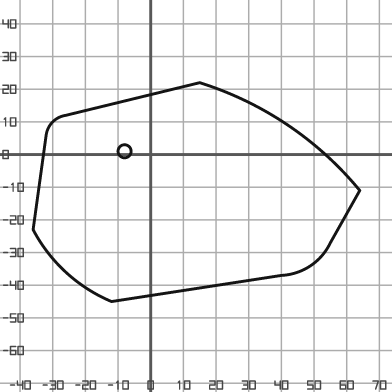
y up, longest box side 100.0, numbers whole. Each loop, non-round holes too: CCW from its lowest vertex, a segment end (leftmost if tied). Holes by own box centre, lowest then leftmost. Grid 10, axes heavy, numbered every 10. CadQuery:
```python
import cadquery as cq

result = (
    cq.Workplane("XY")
    .moveTo(-12.0, -45.0)
    .lineTo(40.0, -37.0)
    .threePointArc((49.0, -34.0), (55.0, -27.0))
    .lineTo(64.0, -11.0)
    .threePointArc((42.0, 9.0), (15.0, 22.0))
    .lineTo(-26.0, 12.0)
    .threePointArc((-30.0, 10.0), (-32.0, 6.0))
    .lineTo(-36.0, -23.0)
    .threePointArc((-26.0, -36.0), (-12.0, -45.0))
    .close()
    .moveTo(-8.0, 1.0)
    .circle(2.0)
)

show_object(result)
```